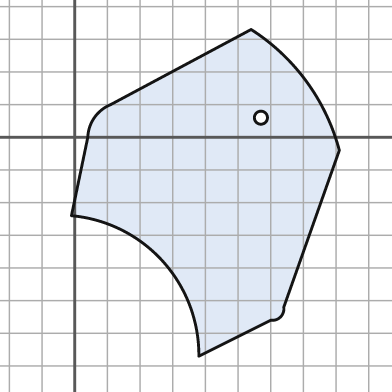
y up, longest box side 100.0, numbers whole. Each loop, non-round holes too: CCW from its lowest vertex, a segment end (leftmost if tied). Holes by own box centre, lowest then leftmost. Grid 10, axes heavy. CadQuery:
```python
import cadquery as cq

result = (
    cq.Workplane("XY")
    .moveTo(38.0, -67.0)
    .lineTo(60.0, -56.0)
    .threePointArc((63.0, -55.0), (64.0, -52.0))
    .lineTo(81.0, -4.0)
    .threePointArc((71.0, 17.0), (54.0, 33.0))
    .lineTo(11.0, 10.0)
    .threePointArc((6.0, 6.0), (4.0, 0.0))
    .lineTo(-1.0, -24.0)
    .threePointArc((27.0, -38.0), (38.0, -67.0))
    .close()
    .moveTo(57.0, 6.0)
    .circle(2.0)
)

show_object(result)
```